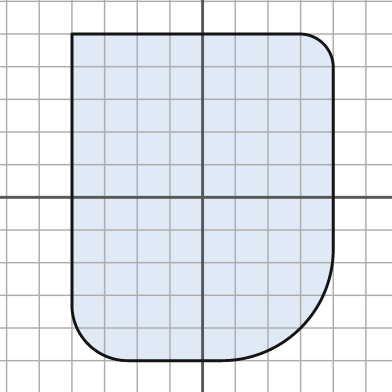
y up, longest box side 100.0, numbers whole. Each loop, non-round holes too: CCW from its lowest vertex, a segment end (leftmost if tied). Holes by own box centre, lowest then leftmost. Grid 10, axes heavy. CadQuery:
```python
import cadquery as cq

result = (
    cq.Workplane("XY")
    .moveTo(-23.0, -50.0)
    .lineTo(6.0, -50.0)
    .threePointArc((30.0, -40.0), (40.0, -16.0))
    .lineTo(40.0, 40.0)
    .threePointArc((37.0, 47.0), (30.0, 50.0))
    .lineTo(-40.0, 50.0)
    .lineTo(-40.0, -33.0)
    .threePointArc((-35.0, -45.0), (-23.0, -50.0))
    .close()
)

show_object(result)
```